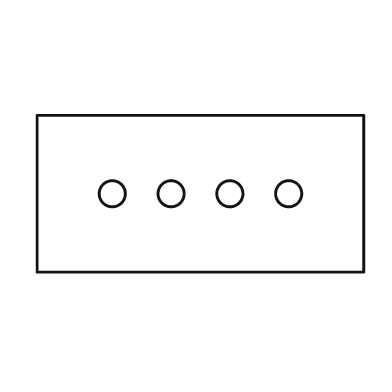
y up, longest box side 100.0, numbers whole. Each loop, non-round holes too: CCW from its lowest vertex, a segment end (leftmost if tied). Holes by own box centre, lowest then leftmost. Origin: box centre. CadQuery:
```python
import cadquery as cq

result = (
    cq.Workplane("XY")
    .moveTo(-50.0, -24.0)
    .lineTo(50.0, -24.0)
    .lineTo(50.0, 24.0)
    .lineTo(-50.0, 24.0)
    .close()
    .moveTo(-27.0, 0.0)
    .circle(4.0)
    .moveTo(-9.0, 0.0)
    .circle(4.0)
    .moveTo(9.0, 0.0)
    .circle(4.0)
    .moveTo(27.0, 0.0)
    .circle(4.0)
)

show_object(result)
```